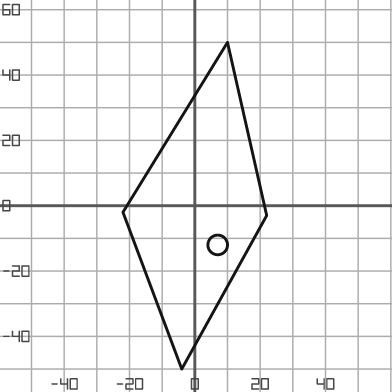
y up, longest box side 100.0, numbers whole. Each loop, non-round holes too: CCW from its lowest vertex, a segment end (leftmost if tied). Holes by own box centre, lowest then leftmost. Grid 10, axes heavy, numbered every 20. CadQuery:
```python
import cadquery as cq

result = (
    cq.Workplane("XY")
    .moveTo(-4.0, -50.0)
    .lineTo(22.0, -3.0)
    .lineTo(10.0, 50.0)
    .lineTo(-22.0, -2.0)
    .close()
    .moveTo(7.0, -12.0)
    .circle(3.0)
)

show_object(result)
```